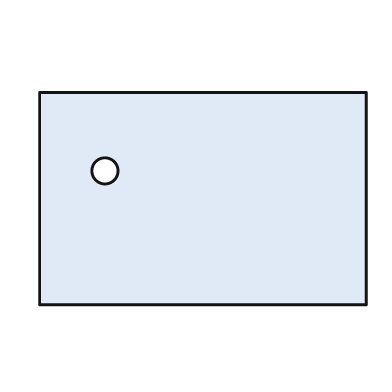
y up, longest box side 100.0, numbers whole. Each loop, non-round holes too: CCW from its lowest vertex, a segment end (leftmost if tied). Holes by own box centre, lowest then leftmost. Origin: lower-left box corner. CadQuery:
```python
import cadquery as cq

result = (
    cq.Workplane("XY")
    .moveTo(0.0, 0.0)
    .lineTo(100.0, 0.0)
    .lineTo(100.0, 65.0)
    .lineTo(0.0, 65.0)
    .close()
    .moveTo(20.0, 41.0)
    .circle(4.0)
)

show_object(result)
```